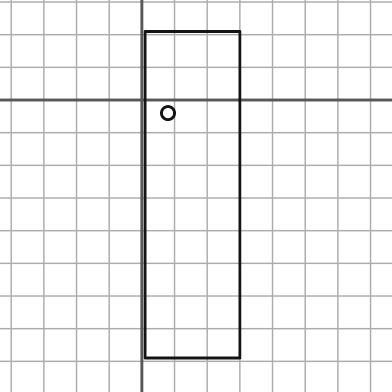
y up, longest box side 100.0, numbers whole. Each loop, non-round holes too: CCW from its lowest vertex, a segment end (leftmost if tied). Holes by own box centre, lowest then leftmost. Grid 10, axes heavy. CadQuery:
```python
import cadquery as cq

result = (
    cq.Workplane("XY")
    .moveTo(1.0, -79.0)
    .lineTo(30.0, -79.0)
    .lineTo(30.0, 21.0)
    .lineTo(1.0, 21.0)
    .close()
    .moveTo(8.0, -4.0)
    .circle(2.0)
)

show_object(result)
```